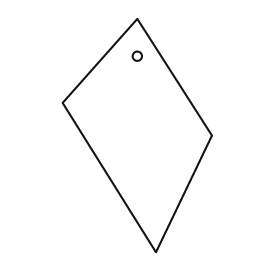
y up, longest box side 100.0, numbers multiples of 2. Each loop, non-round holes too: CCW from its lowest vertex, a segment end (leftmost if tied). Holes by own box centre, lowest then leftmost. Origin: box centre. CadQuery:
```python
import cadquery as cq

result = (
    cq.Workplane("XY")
    .moveTo(8.0, -50.0)
    .lineTo(32.0, 0.0)
    .lineTo(0.0, 50.0)
    .lineTo(-32.0, 14.0)
    .close()
    .moveTo(0.0, 34.0)
    .circle(2.0)
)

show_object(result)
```